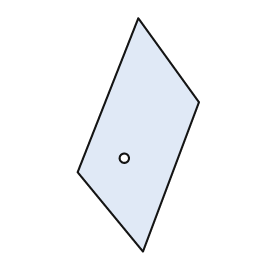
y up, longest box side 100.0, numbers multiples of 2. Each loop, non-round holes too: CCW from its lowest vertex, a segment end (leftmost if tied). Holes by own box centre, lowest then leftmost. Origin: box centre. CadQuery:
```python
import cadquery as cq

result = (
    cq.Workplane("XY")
    .moveTo(2.0, -50.0)
    .lineTo(26.0, 14.0)
    .lineTo(0.0, 50.0)
    .lineTo(-26.0, -16.0)
    .close()
    .moveTo(-6.0, -10.0)
    .circle(2.0)
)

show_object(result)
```